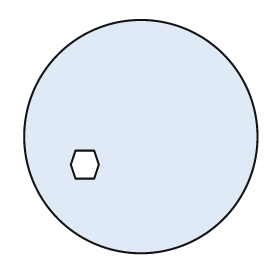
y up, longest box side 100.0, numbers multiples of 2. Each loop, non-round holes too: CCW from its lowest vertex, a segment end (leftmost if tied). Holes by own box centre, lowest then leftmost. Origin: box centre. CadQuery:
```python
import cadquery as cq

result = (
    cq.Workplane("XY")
    .moveTo(0.0, 0.0)
    .circle(50.0)
    .moveTo(-28.0, -18.0)
    .lineTo(-20.0, -18.0)
    .lineTo(-18.0, -12.0)
    .lineTo(-20.0, -6.0)
    .lineTo(-28.0, -6.0)
    .lineTo(-30.0, -12.0)
    .close()
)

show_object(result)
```